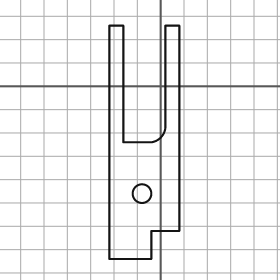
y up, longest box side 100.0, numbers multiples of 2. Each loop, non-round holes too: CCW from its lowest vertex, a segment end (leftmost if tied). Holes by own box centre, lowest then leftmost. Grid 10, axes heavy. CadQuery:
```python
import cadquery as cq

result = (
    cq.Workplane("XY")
    .moveTo(-22.0, -74.0)
    .lineTo(-4.0, -74.0)
    .lineTo(-4.0, -62.0)
    .lineTo(8.0, -62.0)
    .lineTo(8.0, 26.0)
    .lineTo(2.0, 26.0)
    .lineTo(2.0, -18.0)
    .threePointArc((0.0, -22.0), (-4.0, -24.0))
    .lineTo(-16.0, -24.0)
    .lineTo(-16.0, 26.0)
    .lineTo(-22.0, 26.0)
    .close()
    .moveTo(-8.0, -46.0)
    .circle(4.0)
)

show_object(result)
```